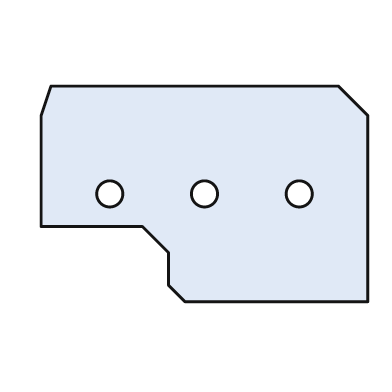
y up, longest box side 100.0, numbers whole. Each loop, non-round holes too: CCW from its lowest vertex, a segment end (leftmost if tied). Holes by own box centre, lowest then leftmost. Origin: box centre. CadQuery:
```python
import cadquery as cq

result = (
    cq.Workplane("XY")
    .moveTo(-6.0, -33.0)
    .lineTo(50.0, -33.0)
    .lineTo(50.0, 24.0)
    .lineTo(41.0, 33.0)
    .lineTo(-47.0, 33.0)
    .lineTo(-50.0, 24.0)
    .lineTo(-50.0, -10.0)
    .lineTo(-19.0, -10.0)
    .lineTo(-11.0, -18.0)
    .lineTo(-11.0, -28.0)
    .close()
    .moveTo(-29.0, 0.0)
    .circle(4.0)
    .moveTo(0.0, 0.0)
    .circle(4.0)
    .moveTo(29.0, 0.0)
    .circle(4.0)
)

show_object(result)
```